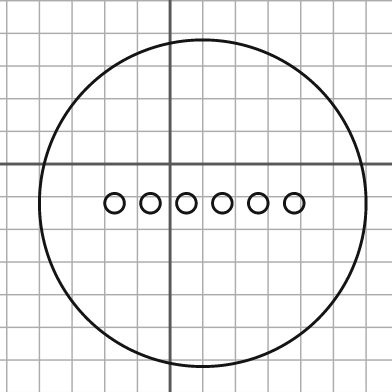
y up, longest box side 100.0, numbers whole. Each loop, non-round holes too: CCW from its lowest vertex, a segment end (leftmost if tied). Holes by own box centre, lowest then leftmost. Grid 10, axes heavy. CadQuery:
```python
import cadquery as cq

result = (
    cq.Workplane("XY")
    .moveTo(10.0, -12.0)
    .circle(50.0)
    .moveTo(-17.0, -12.0)
    .circle(3.0)
    .moveTo(-6.0, -12.0)
    .circle(3.0)
    .moveTo(5.0, -12.0)
    .circle(3.0)
    .moveTo(16.0, -12.0)
    .circle(3.0)
    .moveTo(27.0, -12.0)
    .circle(3.0)
    .moveTo(38.0, -12.0)
    .circle(3.0)
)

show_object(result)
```